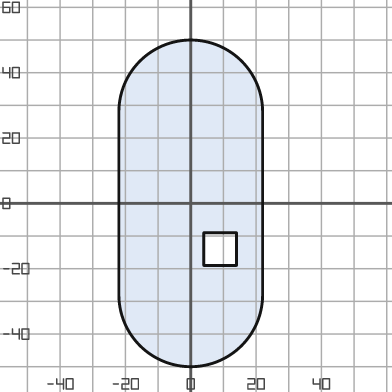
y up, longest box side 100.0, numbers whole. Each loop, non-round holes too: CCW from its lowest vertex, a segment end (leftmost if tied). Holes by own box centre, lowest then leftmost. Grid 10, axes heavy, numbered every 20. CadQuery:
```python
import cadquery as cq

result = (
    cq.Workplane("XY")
    .moveTo(-22.0, -28.0)
    .threePointArc((0.0, -50.0), (22.0, -28.0))
    .lineTo(22.0, 28.0)
    .threePointArc((0.0, 50.0), (-22.0, 28.0))
    .close()
    .moveTo(4.0, -19.0)
    .lineTo(14.0, -19.0)
    .lineTo(14.0, -9.0)
    .lineTo(4.0, -9.0)
    .close()
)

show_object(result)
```